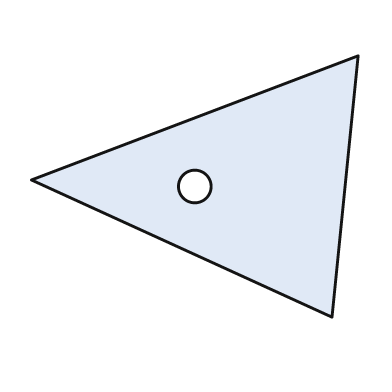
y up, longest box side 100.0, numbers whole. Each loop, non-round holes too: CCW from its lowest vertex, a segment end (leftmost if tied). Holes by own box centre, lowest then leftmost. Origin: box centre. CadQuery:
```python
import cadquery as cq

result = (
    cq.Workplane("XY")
    .moveTo(42.0, -40.0)
    .lineTo(50.0, 40.0)
    .lineTo(-50.0, 2.0)
    .close()
    .moveTo(0.0, 0.0)
    .circle(5.0)
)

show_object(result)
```